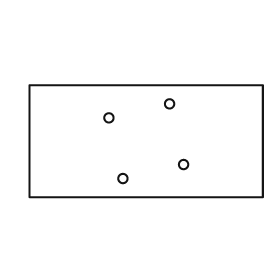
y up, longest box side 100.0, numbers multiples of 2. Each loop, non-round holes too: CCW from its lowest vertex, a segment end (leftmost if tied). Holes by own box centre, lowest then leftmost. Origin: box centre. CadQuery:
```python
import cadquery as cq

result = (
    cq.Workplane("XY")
    .moveTo(-50.0, -24.0)
    .lineTo(50.0, -24.0)
    .lineTo(50.0, 24.0)
    .lineTo(-50.0, 24.0)
    .close()
    .moveTo(-10.0, -16.0)
    .circle(2.0)
    .moveTo(16.0, -10.0)
    .circle(2.0)
    .moveTo(-16.0, 10.0)
    .circle(2.0)
    .moveTo(10.0, 16.0)
    .circle(2.0)
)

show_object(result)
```